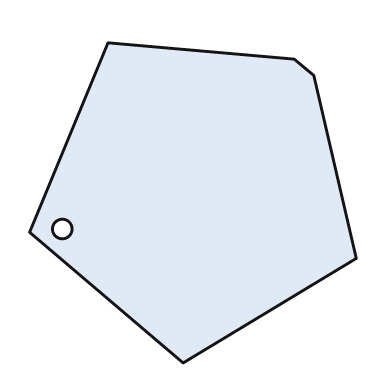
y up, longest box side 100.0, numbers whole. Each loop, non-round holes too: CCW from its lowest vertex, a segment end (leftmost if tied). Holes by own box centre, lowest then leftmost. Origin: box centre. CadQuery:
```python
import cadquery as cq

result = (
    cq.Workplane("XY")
    .moveTo(-3.0, -49.0)
    .lineTo(50.0, -17.0)
    .lineTo(37.0, 39.0)
    .lineTo(31.0, 44.0)
    .lineTo(-26.0, 49.0)
    .lineTo(-50.0, -9.0)
    .close()
    .moveTo(-40.0, -8.0)
    .circle(3.0)
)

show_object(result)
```